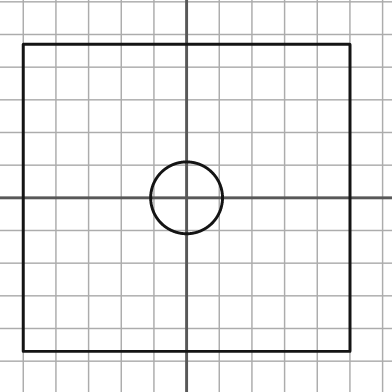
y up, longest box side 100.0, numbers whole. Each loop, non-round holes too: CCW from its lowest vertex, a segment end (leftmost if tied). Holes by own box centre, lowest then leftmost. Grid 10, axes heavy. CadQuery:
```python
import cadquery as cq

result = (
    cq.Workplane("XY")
    .moveTo(-50.0, -47.0)
    .lineTo(50.0, -47.0)
    .lineTo(50.0, 47.0)
    .lineTo(-50.0, 47.0)
    .close()
    .moveTo(0.0, 0.0)
    .circle(11.0)
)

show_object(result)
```